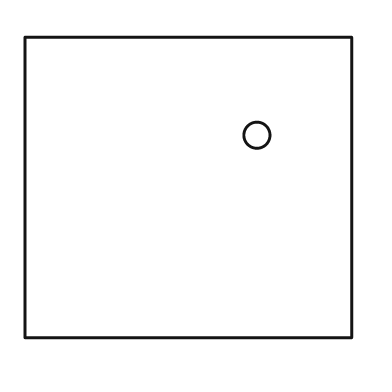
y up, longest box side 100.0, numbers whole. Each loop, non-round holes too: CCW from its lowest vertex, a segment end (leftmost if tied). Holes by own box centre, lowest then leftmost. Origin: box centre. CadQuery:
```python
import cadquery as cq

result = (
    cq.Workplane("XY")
    .moveTo(-50.0, -46.0)
    .lineTo(50.0, -46.0)
    .lineTo(50.0, 46.0)
    .lineTo(-50.0, 46.0)
    .close()
    .moveTo(21.0, 16.0)
    .circle(4.0)
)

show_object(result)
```